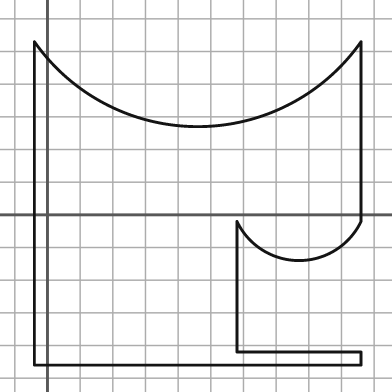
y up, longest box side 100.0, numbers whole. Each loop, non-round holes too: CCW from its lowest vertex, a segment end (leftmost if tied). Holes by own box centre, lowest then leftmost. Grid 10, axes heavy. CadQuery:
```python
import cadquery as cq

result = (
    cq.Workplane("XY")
    .moveTo(-4.0, -46.0)
    .lineTo(96.0, -46.0)
    .lineTo(96.0, -42.0)
    .lineTo(58.0, -42.0)
    .lineTo(58.0, -2.0)
    .threePointArc((77.0, -14.0), (96.0, -2.0))
    .lineTo(96.0, 53.0)
    .threePointArc((46.0, 27.0), (-4.0, 53.0))
    .close()
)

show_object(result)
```